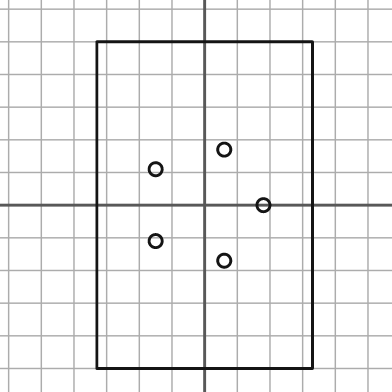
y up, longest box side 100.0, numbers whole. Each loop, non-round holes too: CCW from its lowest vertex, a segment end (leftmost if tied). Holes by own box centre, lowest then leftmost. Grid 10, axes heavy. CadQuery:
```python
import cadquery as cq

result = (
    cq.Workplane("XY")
    .moveTo(-33.0, -50.0)
    .lineTo(33.0, -50.0)
    .lineTo(33.0, 50.0)
    .lineTo(-33.0, 50.0)
    .close()
    .moveTo(6.0, -17.0)
    .circle(2.0)
    .moveTo(-15.0, -11.0)
    .circle(2.0)
    .moveTo(18.0, 0.0)
    .circle(2.0)
    .moveTo(-15.0, 11.0)
    .circle(2.0)
    .moveTo(6.0, 17.0)
    .circle(2.0)
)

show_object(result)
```